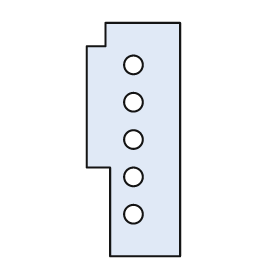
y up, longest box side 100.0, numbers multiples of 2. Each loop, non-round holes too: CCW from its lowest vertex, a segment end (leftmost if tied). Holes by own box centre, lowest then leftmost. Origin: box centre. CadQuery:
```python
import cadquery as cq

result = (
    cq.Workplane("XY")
    .moveTo(-10.0, -50.0)
    .lineTo(20.0, -50.0)
    .lineTo(20.0, 50.0)
    .lineTo(-12.0, 50.0)
    .lineTo(-12.0, 40.0)
    .lineTo(-20.0, 40.0)
    .lineTo(-20.0, -12.0)
    .lineTo(-10.0, -12.0)
    .close()
    .moveTo(0.0, -32.0)
    .circle(4.0)
    .moveTo(0.0, -16.0)
    .circle(4.0)
    .moveTo(0.0, 0.0)
    .circle(4.0)
    .moveTo(0.0, 16.0)
    .circle(4.0)
    .moveTo(0.0, 32.0)
    .circle(4.0)
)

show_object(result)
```